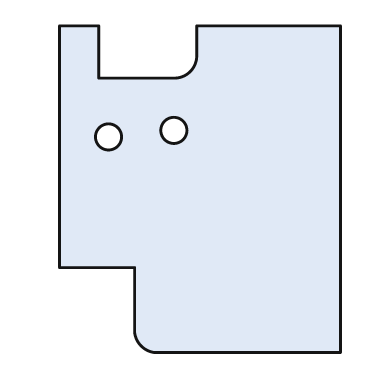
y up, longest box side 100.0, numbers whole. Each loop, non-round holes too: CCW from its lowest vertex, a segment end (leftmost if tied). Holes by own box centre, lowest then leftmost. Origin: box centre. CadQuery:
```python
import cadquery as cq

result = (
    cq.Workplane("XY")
    .moveTo(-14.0, -50.0)
    .lineTo(43.0, -50.0)
    .lineTo(43.0, 50.0)
    .lineTo(-1.0, 50.0)
    .lineTo(-1.0, 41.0)
    .threePointArc((-3.0, 36.0), (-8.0, 34.0))
    .lineTo(-31.0, 34.0)
    .lineTo(-31.0, 50.0)
    .lineTo(-43.0, 50.0)
    .lineTo(-43.0, -24.0)
    .lineTo(-20.0, -24.0)
    .lineTo(-20.0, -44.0)
    .threePointArc((-18.0, -48.0), (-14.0, -50.0))
    .close()
    .moveTo(-28.0, 16.0)
    .circle(4.0)
    .moveTo(-8.0, 18.0)
    .circle(4.0)
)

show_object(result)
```